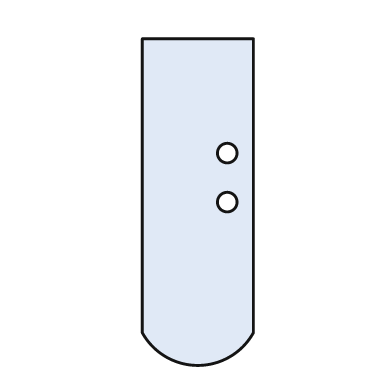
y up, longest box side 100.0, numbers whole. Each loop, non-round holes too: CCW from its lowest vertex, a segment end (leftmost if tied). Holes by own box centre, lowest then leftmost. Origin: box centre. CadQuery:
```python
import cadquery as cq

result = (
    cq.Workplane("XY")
    .moveTo(-17.0, -40.0)
    .threePointArc((0.0, -50.0), (17.0, -40.0))
    .lineTo(17.0, 50.0)
    .lineTo(-17.0, 50.0)
    .close()
    .moveTo(9.0, 0.0)
    .circle(3.0)
    .moveTo(9.0, 15.0)
    .circle(3.0)
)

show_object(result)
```